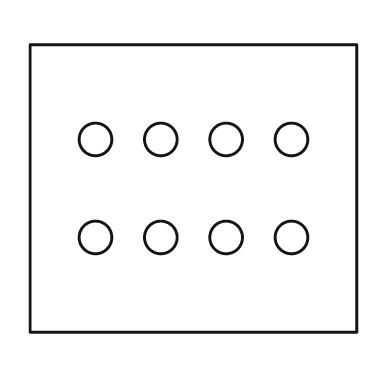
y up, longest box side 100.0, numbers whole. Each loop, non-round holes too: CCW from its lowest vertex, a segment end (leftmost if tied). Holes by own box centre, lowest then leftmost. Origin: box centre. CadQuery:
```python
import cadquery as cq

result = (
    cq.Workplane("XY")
    .moveTo(-50.0, -44.0)
    .lineTo(50.0, -44.0)
    .lineTo(50.0, 44.0)
    .lineTo(-50.0, 44.0)
    .close()
    .moveTo(-30.0, -15.0)
    .circle(5.0)
    .moveTo(-10.0, -15.0)
    .circle(5.0)
    .moveTo(10.0, -15.0)
    .circle(5.0)
    .moveTo(30.0, -15.0)
    .circle(5.0)
    .moveTo(-30.0, 15.0)
    .circle(5.0)
    .moveTo(-10.0, 15.0)
    .circle(5.0)
    .moveTo(10.0, 15.0)
    .circle(5.0)
    .moveTo(30.0, 15.0)
    .circle(5.0)
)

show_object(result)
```